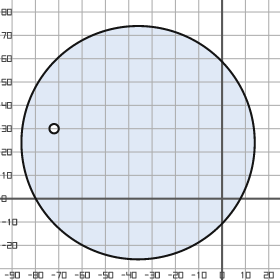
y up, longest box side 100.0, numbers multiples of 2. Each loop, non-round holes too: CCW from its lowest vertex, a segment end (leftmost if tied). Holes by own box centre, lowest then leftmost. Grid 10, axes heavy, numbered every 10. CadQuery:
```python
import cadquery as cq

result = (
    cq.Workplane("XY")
    .moveTo(-36.0, 24.0)
    .circle(50.0)
    .moveTo(-72.0, 30.0)
    .circle(2.0)
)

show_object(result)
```